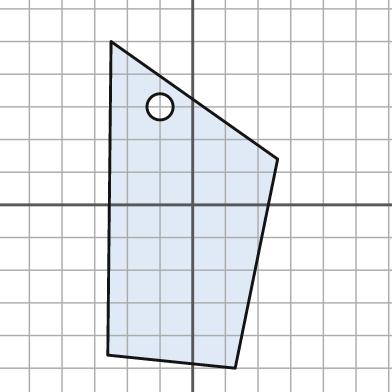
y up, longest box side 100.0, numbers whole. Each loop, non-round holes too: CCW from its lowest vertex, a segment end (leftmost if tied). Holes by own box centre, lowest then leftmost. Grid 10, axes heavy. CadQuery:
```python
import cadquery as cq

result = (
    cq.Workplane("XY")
    .moveTo(13.0, -50.0)
    .lineTo(26.0, 14.0)
    .lineTo(-25.0, 50.0)
    .lineTo(-26.0, -46.0)
    .close()
    .moveTo(-10.0, 30.0)
    .circle(4.0)
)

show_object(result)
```